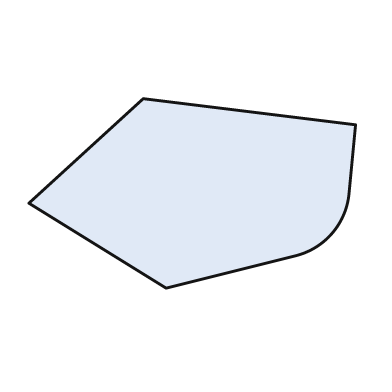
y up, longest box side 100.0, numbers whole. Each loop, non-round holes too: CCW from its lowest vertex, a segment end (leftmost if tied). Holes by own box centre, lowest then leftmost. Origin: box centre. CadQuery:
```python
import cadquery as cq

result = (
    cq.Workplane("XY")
    .moveTo(-8.0, -29.0)
    .lineTo(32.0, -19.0)
    .threePointArc((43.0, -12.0), (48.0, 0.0))
    .lineTo(50.0, 21.0)
    .lineTo(-15.0, 29.0)
    .lineTo(-50.0, -3.0)
    .close()
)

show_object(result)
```